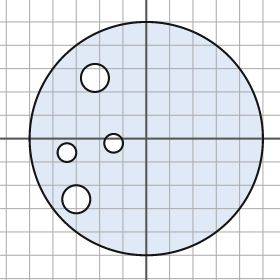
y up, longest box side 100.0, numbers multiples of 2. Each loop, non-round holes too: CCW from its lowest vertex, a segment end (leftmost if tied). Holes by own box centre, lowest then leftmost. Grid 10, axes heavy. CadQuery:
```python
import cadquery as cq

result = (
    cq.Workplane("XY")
    .moveTo(0.0, 0.0)
    .circle(50.0)
    .moveTo(-30.0, -26.0)
    .circle(6.0)
    .moveTo(-34.0, -6.0)
    .circle(4.0)
    .moveTo(-14.0, -2.0)
    .circle(4.0)
    .moveTo(-22.0, 26.0)
    .circle(6.0)
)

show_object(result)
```